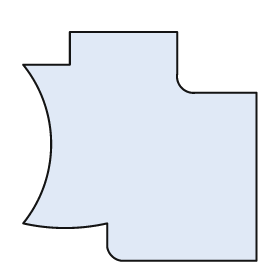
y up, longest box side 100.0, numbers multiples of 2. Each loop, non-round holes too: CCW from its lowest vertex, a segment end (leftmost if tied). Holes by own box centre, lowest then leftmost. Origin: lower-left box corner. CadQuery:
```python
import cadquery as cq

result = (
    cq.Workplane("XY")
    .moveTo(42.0, 0.0)
    .lineTo(100.0, 0.0)
    .lineTo(100.0, 72.0)
    .lineTo(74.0, 72.0)
    .threePointArc((68.0, 74.0), (66.0, 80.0))
    .lineTo(66.0, 98.0)
    .lineTo(20.0, 98.0)
    .lineTo(20.0, 84.0)
    .lineTo(0.0, 84.0)
    .threePointArc((12.0, 50.0), (0.0, 16.0))
    .threePointArc((18.0, 14.0), (36.0, 16.0))
    .lineTo(36.0, 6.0)
    .threePointArc((38.0, 2.0), (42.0, 0.0))
    .close()
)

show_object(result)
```